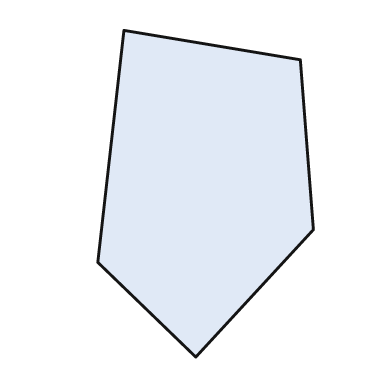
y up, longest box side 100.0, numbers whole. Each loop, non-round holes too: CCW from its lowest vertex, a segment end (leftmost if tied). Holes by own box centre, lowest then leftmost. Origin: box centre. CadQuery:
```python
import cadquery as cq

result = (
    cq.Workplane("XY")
    .moveTo(-3.0, -50.0)
    .lineTo(33.0, -11.0)
    .lineTo(29.0, 41.0)
    .lineTo(-25.0, 50.0)
    .lineTo(-33.0, -21.0)
    .close()
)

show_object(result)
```